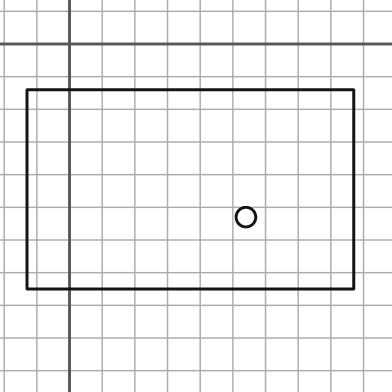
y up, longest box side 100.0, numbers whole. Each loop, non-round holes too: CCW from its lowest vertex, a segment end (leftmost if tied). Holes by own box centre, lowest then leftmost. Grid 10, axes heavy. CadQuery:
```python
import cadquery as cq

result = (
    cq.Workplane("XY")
    .moveTo(-13.0, -75.0)
    .lineTo(87.0, -75.0)
    .lineTo(87.0, -14.0)
    .lineTo(-13.0, -14.0)
    .close()
    .moveTo(54.0, -53.0)
    .circle(3.0)
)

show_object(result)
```